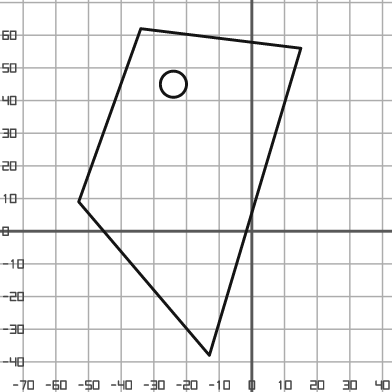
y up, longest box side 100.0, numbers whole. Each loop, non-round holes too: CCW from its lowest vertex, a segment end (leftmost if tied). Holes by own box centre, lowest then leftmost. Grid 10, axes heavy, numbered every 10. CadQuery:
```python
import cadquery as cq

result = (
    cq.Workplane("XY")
    .moveTo(-13.0, -38.0)
    .lineTo(15.0, 56.0)
    .lineTo(-34.0, 62.0)
    .lineTo(-53.0, 9.0)
    .close()
    .moveTo(-24.0, 45.0)
    .circle(4.0)
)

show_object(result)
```